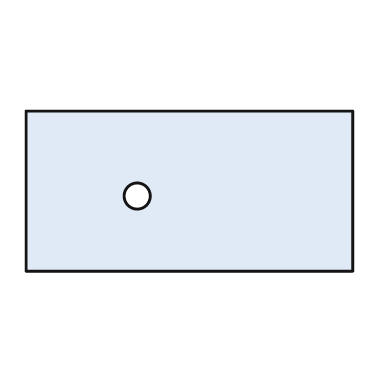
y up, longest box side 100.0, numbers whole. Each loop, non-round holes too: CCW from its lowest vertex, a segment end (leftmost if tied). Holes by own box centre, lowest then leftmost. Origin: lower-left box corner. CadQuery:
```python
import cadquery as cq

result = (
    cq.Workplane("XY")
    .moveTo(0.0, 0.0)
    .lineTo(100.0, 0.0)
    .lineTo(100.0, 49.0)
    .lineTo(0.0, 49.0)
    .close()
    .moveTo(34.0, 23.0)
    .circle(4.0)
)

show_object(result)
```